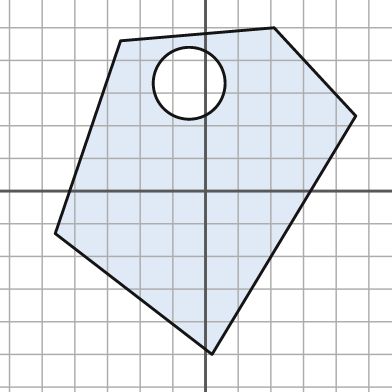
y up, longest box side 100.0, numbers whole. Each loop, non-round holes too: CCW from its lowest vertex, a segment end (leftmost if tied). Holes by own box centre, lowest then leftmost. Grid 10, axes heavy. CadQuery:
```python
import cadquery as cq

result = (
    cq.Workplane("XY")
    .moveTo(2.0, -50.0)
    .lineTo(46.0, 23.0)
    .lineTo(21.0, 50.0)
    .lineTo(-26.0, 46.0)
    .lineTo(-46.0, -13.0)
    .close()
    .moveTo(-5.0, 33.0)
    .circle(11.0)
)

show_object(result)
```